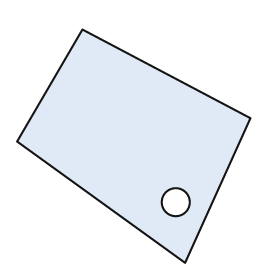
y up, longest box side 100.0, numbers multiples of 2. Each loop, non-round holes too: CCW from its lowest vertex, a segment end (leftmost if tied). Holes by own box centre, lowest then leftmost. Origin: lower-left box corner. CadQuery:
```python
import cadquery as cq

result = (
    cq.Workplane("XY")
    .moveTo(72.0, 0.0)
    .lineTo(100.0, 62.0)
    .lineTo(28.0, 100.0)
    .lineTo(0.0, 52.0)
    .close()
    .moveTo(68.0, 26.0)
    .circle(6.0)
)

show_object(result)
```